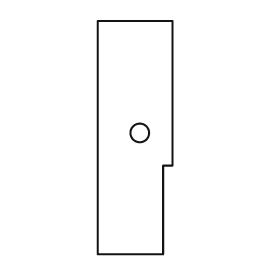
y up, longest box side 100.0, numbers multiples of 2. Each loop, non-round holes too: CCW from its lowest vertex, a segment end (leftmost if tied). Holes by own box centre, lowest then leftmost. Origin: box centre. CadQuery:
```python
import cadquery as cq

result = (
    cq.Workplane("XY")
    .moveTo(-16.0, -50.0)
    .lineTo(12.0, -50.0)
    .lineTo(12.0, -12.0)
    .lineTo(16.0, -12.0)
    .lineTo(16.0, 50.0)
    .lineTo(-16.0, 50.0)
    .close()
    .moveTo(2.0, 2.0)
    .circle(4.0)
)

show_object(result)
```